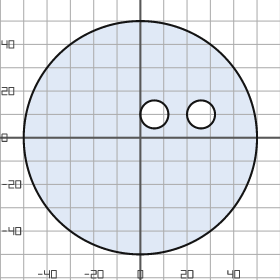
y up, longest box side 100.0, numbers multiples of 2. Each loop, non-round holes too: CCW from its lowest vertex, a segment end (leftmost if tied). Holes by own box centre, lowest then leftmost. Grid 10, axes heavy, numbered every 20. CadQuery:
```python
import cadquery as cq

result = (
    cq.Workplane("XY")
    .moveTo(0.0, 0.0)
    .circle(50.0)
    .moveTo(6.0, 10.0)
    .circle(6.0)
    .moveTo(26.0, 10.0)
    .circle(6.0)
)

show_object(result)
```